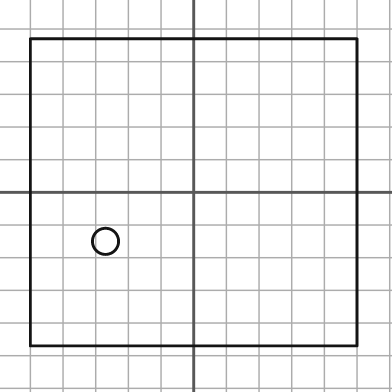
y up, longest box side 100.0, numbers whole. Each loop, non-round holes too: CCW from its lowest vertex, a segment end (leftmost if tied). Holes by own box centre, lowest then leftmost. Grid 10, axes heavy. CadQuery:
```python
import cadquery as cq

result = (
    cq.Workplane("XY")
    .moveTo(-50.0, -47.0)
    .lineTo(50.0, -47.0)
    .lineTo(50.0, 47.0)
    .lineTo(-50.0, 47.0)
    .close()
    .moveTo(-27.0, -15.0)
    .circle(4.0)
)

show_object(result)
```